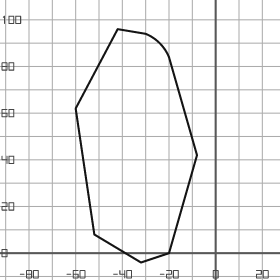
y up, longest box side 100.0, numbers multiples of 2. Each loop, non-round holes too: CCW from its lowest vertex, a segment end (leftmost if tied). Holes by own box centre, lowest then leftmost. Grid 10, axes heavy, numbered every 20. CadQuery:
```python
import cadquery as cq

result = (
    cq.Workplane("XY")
    .moveTo(-32.0, -4.0)
    .lineTo(-20.0, 0.0)
    .lineTo(-8.0, 42.0)
    .lineTo(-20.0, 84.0)
    .threePointArc((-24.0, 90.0), (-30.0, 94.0))
    .lineTo(-42.0, 96.0)
    .lineTo(-60.0, 62.0)
    .lineTo(-52.0, 8.0)
    .close()
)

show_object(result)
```